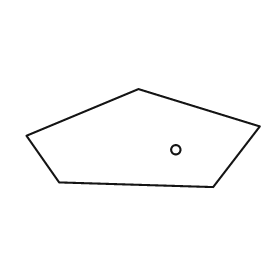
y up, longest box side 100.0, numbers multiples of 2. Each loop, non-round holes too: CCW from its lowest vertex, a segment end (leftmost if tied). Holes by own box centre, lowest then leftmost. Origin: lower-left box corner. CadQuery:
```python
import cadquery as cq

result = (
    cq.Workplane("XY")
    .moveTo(80.0, 0.0)
    .lineTo(100.0, 26.0)
    .lineTo(48.0, 42.0)
    .lineTo(0.0, 22.0)
    .lineTo(14.0, 2.0)
    .close()
    .moveTo(64.0, 16.0)
    .circle(2.0)
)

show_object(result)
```